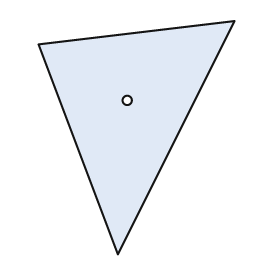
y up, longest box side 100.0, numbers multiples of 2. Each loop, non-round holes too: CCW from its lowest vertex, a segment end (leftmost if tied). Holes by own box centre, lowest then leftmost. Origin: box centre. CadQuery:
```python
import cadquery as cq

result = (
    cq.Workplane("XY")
    .moveTo(-8.0, -50.0)
    .lineTo(42.0, 50.0)
    .lineTo(-42.0, 40.0)
    .close()
    .moveTo(-4.0, 16.0)
    .circle(2.0)
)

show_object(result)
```